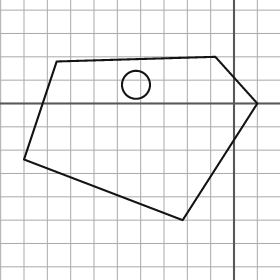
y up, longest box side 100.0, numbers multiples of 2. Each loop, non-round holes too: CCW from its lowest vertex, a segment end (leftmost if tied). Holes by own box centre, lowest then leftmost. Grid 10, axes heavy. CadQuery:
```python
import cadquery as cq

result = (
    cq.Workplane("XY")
    .moveTo(-22.0, -50.0)
    .lineTo(10.0, 0.0)
    .lineTo(-8.0, 20.0)
    .lineTo(-76.0, 18.0)
    .lineTo(-90.0, -24.0)
    .close()
    .moveTo(-42.0, 8.0)
    .circle(6.0)
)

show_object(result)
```